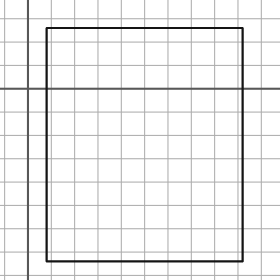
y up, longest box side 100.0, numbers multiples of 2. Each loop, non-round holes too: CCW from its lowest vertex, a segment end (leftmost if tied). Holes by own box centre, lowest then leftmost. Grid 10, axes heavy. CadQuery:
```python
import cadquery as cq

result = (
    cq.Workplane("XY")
    .moveTo(8.0, -74.0)
    .lineTo(92.0, -74.0)
    .lineTo(92.0, 26.0)
    .lineTo(8.0, 26.0)
    .close()
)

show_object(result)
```